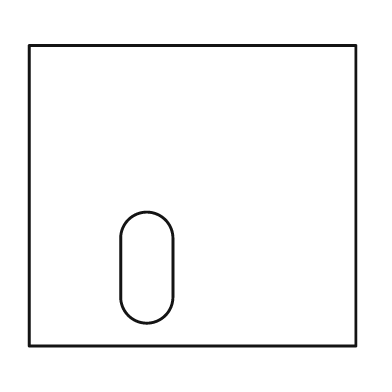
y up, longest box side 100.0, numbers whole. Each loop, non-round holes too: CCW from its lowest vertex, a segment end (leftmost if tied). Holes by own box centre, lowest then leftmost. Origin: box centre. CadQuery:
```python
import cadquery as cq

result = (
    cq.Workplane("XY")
    .moveTo(-50.0, -46.0)
    .lineTo(50.0, -46.0)
    .lineTo(50.0, 46.0)
    .lineTo(-50.0, 46.0)
    .close()
    .moveTo(-22.0, -31.0)
    .threePointArc((-14.0, -39.0), (-6.0, -31.0))
    .lineTo(-6.0, -13.0)
    .threePointArc((-14.0, -5.0), (-22.0, -13.0))
    .close()
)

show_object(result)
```